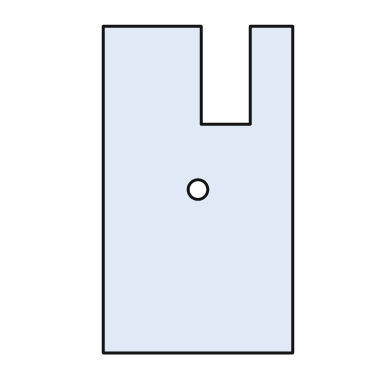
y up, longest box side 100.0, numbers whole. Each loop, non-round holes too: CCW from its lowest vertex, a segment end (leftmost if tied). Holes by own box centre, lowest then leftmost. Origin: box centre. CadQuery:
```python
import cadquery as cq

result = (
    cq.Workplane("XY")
    .moveTo(-29.0, -50.0)
    .lineTo(29.0, -50.0)
    .lineTo(29.0, 50.0)
    .lineTo(16.0, 50.0)
    .lineTo(16.0, 20.0)
    .lineTo(1.0, 20.0)
    .lineTo(1.0, 50.0)
    .lineTo(-29.0, 50.0)
    .close()
    .moveTo(0.0, 0.0)
    .circle(3.0)
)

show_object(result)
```